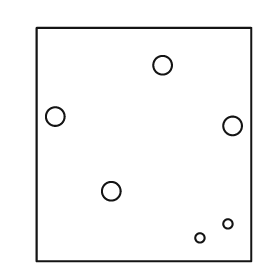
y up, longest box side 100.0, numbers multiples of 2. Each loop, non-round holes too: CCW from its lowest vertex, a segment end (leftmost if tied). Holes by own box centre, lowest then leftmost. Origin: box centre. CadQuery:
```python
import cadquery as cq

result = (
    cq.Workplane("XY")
    .moveTo(-46.0, -50.0)
    .lineTo(46.0, -50.0)
    .lineTo(46.0, 50.0)
    .lineTo(-46.0, 50.0)
    .close()
    .moveTo(24.0, -40.0)
    .circle(2.0)
    .moveTo(36.0, -34.0)
    .circle(2.0)
    .moveTo(-14.0, -20.0)
    .circle(4.0)
    .moveTo(38.0, 8.0)
    .circle(4.0)
    .moveTo(-38.0, 12.0)
    .circle(4.0)
    .moveTo(8.0, 34.0)
    .circle(4.0)
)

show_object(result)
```